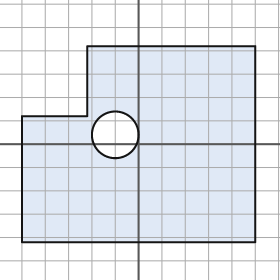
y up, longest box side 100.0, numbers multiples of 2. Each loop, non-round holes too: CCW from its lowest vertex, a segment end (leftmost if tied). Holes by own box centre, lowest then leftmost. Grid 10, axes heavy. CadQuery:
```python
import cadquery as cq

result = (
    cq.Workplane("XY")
    .moveTo(-50.0, -42.0)
    .lineTo(50.0, -42.0)
    .lineTo(50.0, 42.0)
    .lineTo(-22.0, 42.0)
    .lineTo(-22.0, 12.0)
    .lineTo(-50.0, 12.0)
    .close()
    .moveTo(-10.0, 4.0)
    .circle(10.0)
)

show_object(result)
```